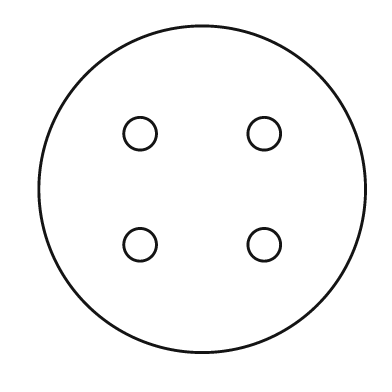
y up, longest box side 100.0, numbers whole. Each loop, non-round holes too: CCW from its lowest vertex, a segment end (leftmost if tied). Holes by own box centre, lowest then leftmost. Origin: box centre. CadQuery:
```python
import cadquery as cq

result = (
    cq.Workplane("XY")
    .moveTo(0.0, 0.0)
    .circle(50.0)
    .moveTo(-19.0, -17.0)
    .circle(5.0)
    .moveTo(19.0, -17.0)
    .circle(5.0)
    .moveTo(-19.0, 17.0)
    .circle(5.0)
    .moveTo(19.0, 17.0)
    .circle(5.0)
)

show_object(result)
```